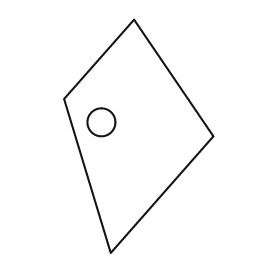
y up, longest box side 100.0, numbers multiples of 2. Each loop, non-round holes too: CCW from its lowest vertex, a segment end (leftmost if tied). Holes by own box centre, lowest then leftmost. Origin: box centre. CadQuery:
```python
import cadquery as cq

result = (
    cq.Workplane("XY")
    .moveTo(-12.0, -50.0)
    .lineTo(32.0, 0.0)
    .lineTo(-2.0, 50.0)
    .lineTo(-32.0, 16.0)
    .close()
    .moveTo(-16.0, 6.0)
    .circle(6.0)
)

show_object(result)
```